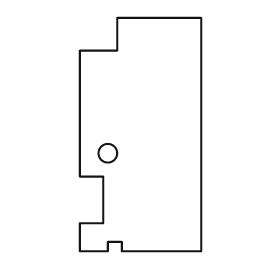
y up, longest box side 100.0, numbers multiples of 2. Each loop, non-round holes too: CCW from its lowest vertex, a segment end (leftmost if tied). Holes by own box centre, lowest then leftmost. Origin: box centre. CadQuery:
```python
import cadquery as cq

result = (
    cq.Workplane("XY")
    .moveTo(-26.0, -50.0)
    .lineTo(-14.0, -50.0)
    .lineTo(-14.0, -46.0)
    .lineTo(-8.0, -46.0)
    .lineTo(-8.0, -50.0)
    .lineTo(26.0, -50.0)
    .lineTo(26.0, 50.0)
    .lineTo(-10.0, 50.0)
    .lineTo(-10.0, 36.0)
    .lineTo(-26.0, 36.0)
    .lineTo(-26.0, -18.0)
    .lineTo(-16.0, -18.0)
    .lineTo(-16.0, -38.0)
    .lineTo(-26.0, -38.0)
    .close()
    .moveTo(-14.0, -8.0)
    .circle(4.0)
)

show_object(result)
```